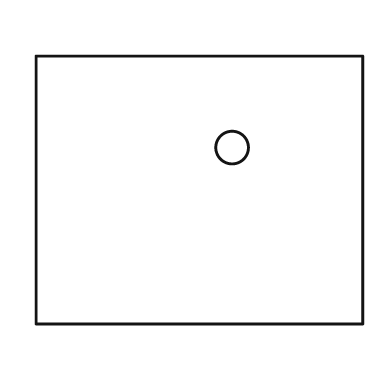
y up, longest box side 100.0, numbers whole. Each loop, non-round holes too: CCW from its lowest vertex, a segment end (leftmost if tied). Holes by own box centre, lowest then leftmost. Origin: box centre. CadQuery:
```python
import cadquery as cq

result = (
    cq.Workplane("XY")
    .moveTo(-50.0, -41.0)
    .lineTo(50.0, -41.0)
    .lineTo(50.0, 41.0)
    .lineTo(-50.0, 41.0)
    .close()
    .moveTo(10.0, 13.0)
    .circle(5.0)
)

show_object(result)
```